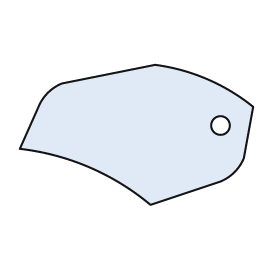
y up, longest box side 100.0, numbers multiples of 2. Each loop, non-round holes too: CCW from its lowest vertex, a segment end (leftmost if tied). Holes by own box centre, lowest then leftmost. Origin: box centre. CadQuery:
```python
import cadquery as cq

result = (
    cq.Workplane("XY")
    .moveTo(6.0, -30.0)
    .lineTo(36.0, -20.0)
    .threePointArc((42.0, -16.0), (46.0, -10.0))
    .lineTo(50.0, 12.0)
    .threePointArc((30.0, 24.0), (8.0, 30.0))
    .lineTo(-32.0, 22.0)
    .threePointArc((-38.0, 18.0), (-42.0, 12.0))
    .lineTo(-50.0, -6.0)
    .threePointArc((-20.0, -14.0), (6.0, -30.0))
    .close()
    .moveTo(36.0, 4.0)
    .circle(4.0)
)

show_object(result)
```